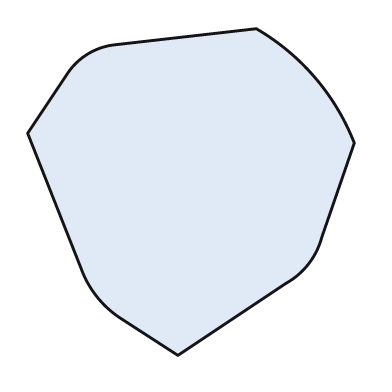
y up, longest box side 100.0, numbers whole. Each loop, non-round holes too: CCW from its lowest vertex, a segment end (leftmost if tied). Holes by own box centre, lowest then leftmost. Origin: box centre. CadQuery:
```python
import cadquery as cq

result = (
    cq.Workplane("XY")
    .moveTo(-4.0, -50.0)
    .lineTo(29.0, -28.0)
    .threePointArc((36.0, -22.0), (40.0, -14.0))
    .lineTo(50.0, 15.0)
    .threePointArc((38.0, 35.0), (20.0, 50.0))
    .lineTo(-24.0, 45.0)
    .threePointArc((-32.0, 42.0), (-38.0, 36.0))
    .lineTo(-50.0, 18.0)
    .lineTo(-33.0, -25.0)
    .threePointArc((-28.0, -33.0), (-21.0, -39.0))
    .close()
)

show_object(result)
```